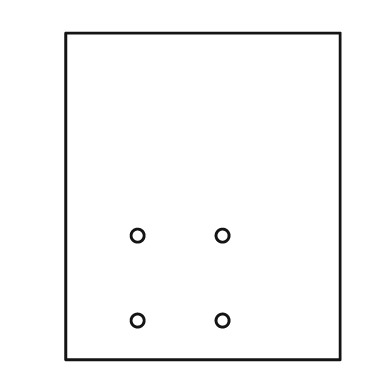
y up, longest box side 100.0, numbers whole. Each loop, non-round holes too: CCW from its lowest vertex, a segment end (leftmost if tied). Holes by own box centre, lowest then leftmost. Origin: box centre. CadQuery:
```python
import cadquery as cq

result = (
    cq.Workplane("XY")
    .moveTo(-42.0, -50.0)
    .lineTo(42.0, -50.0)
    .lineTo(42.0, 50.0)
    .lineTo(-42.0, 50.0)
    .close()
    .moveTo(-20.0, -38.0)
    .circle(2.0)
    .moveTo(6.0, -38.0)
    .circle(2.0)
    .moveTo(-20.0, -12.0)
    .circle(2.0)
    .moveTo(6.0, -12.0)
    .circle(2.0)
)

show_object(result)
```